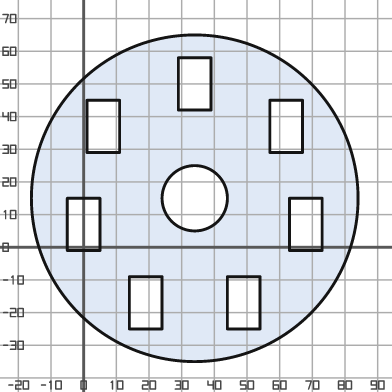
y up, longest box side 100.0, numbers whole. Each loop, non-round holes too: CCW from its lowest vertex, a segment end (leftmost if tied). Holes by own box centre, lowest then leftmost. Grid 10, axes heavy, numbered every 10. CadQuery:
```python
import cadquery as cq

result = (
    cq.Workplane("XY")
    .moveTo(34.0, 15.0)
    .circle(50.0)
    .moveTo(14.0, -25.0)
    .lineTo(24.0, -25.0)
    .lineTo(24.0, -9.0)
    .lineTo(14.0, -9.0)
    .close()
    .moveTo(44.0, -25.0)
    .lineTo(54.0, -25.0)
    .lineTo(54.0, -9.0)
    .lineTo(44.0, -9.0)
    .close()
    .moveTo(-5.0, -1.0)
    .lineTo(5.0, -1.0)
    .lineTo(5.0, 15.0)
    .lineTo(-5.0, 15.0)
    .close()
    .moveTo(63.0, -1.0)
    .lineTo(73.0, -1.0)
    .lineTo(73.0, 15.0)
    .lineTo(63.0, 15.0)
    .close()
    .moveTo(34.0, 15.0)
    .circle(10.0)
    .moveTo(1.0, 29.0)
    .lineTo(11.0, 29.0)
    .lineTo(11.0, 45.0)
    .lineTo(1.0, 45.0)
    .close()
    .moveTo(57.0, 29.0)
    .lineTo(67.0, 29.0)
    .lineTo(67.0, 45.0)
    .lineTo(57.0, 45.0)
    .close()
    .moveTo(29.0, 42.0)
    .lineTo(39.0, 42.0)
    .lineTo(39.0, 58.0)
    .lineTo(29.0, 58.0)
    .close()
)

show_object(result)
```